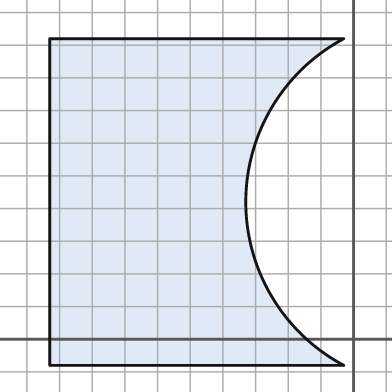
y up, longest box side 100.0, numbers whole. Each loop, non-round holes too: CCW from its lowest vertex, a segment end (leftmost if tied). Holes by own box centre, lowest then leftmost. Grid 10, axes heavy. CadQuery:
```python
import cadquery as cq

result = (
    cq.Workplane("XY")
    .moveTo(-93.0, -8.0)
    .lineTo(-3.0, -8.0)
    .threePointArc((-33.0, 42.0), (-3.0, 92.0))
    .lineTo(-93.0, 92.0)
    .close()
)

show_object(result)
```